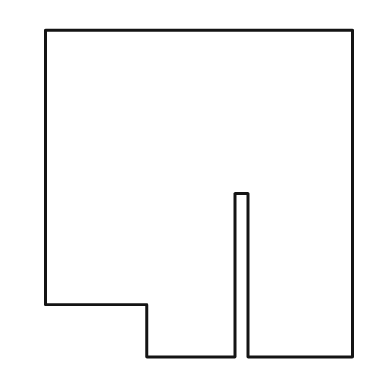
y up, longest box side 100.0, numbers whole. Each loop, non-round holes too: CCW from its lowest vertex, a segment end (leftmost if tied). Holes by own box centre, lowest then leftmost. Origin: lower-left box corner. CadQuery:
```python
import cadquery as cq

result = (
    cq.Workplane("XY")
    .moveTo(31.0, 0.0)
    .lineTo(58.0, 0.0)
    .lineTo(58.0, 50.0)
    .lineTo(62.0, 50.0)
    .lineTo(62.0, 0.0)
    .lineTo(94.0, 0.0)
    .lineTo(94.0, 100.0)
    .lineTo(0.0, 100.0)
    .lineTo(0.0, 16.0)
    .lineTo(31.0, 16.0)
    .close()
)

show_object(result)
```